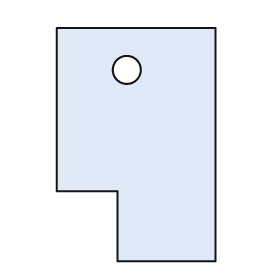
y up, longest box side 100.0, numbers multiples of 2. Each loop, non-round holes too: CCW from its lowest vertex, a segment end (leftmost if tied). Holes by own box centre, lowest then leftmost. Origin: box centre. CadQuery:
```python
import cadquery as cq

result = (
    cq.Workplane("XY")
    .moveTo(-8.0, -50.0)
    .lineTo(34.0, -50.0)
    .lineTo(34.0, 50.0)
    .lineTo(-34.0, 50.0)
    .lineTo(-34.0, -20.0)
    .lineTo(-8.0, -20.0)
    .close()
    .moveTo(-4.0, 32.0)
    .circle(6.0)
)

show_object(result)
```